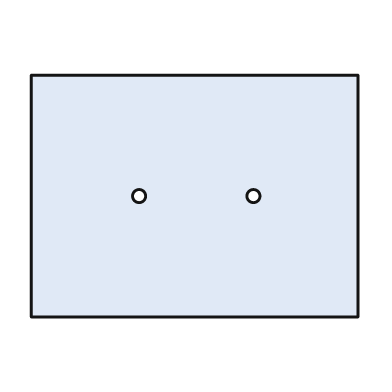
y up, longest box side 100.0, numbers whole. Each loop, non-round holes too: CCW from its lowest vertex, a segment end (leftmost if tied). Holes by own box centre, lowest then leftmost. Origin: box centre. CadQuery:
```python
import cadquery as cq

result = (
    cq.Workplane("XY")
    .moveTo(-50.0, -37.0)
    .lineTo(50.0, -37.0)
    .lineTo(50.0, 37.0)
    .lineTo(-50.0, 37.0)
    .close()
    .moveTo(-17.0, 0.0)
    .circle(2.0)
    .moveTo(18.0, 0.0)
    .circle(2.0)
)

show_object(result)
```